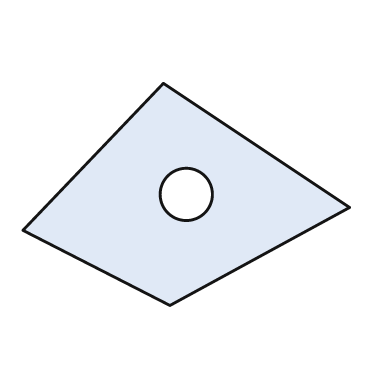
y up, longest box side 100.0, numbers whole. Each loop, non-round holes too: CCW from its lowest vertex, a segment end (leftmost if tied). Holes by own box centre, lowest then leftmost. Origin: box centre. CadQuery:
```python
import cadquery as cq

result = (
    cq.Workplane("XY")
    .moveTo(-5.0, -34.0)
    .lineTo(50.0, -4.0)
    .lineTo(-7.0, 34.0)
    .lineTo(-50.0, -11.0)
    .close()
    .moveTo(0.0, 0.0)
    .circle(8.0)
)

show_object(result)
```